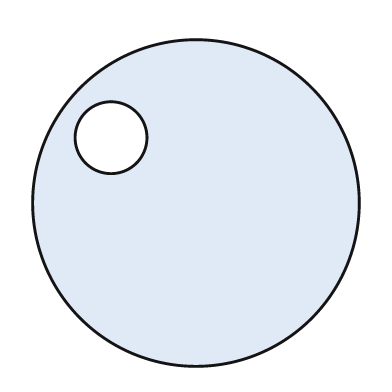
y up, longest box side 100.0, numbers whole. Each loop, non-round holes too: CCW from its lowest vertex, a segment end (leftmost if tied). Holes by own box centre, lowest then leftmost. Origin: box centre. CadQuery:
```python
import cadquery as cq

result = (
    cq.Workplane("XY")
    .moveTo(0.0, 0.0)
    .circle(50.0)
    .moveTo(-26.0, 20.0)
    .circle(11.0)
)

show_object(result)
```